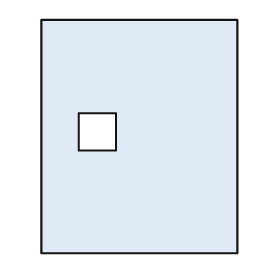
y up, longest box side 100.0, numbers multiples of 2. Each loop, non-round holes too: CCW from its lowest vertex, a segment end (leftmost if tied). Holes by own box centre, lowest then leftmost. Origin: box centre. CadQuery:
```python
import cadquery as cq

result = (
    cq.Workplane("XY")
    .moveTo(-42.0, -50.0)
    .lineTo(42.0, -50.0)
    .lineTo(42.0, 50.0)
    .lineTo(-42.0, 50.0)
    .close()
    .moveTo(-26.0, -6.0)
    .lineTo(-10.0, -6.0)
    .lineTo(-10.0, 10.0)
    .lineTo(-26.0, 10.0)
    .close()
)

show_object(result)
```